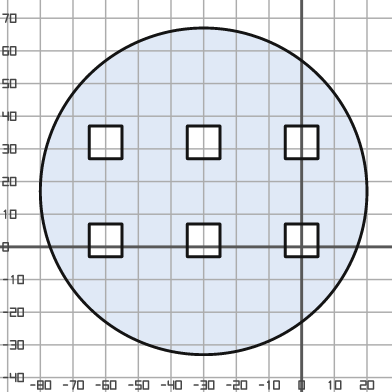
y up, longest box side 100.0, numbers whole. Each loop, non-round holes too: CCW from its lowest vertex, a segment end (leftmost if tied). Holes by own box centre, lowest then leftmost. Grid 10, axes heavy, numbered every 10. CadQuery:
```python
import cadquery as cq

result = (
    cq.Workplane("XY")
    .moveTo(-30.0, 17.0)
    .circle(50.0)
    .moveTo(-65.0, -3.0)
    .lineTo(-55.0, -3.0)
    .lineTo(-55.0, 7.0)
    .lineTo(-65.0, 7.0)
    .close()
    .moveTo(-35.0, -3.0)
    .lineTo(-25.0, -3.0)
    .lineTo(-25.0, 7.0)
    .lineTo(-35.0, 7.0)
    .close()
    .moveTo(-5.0, -3.0)
    .lineTo(5.0, -3.0)
    .lineTo(5.0, 7.0)
    .lineTo(-5.0, 7.0)
    .close()
    .moveTo(-65.0, 27.0)
    .lineTo(-55.0, 27.0)
    .lineTo(-55.0, 37.0)
    .lineTo(-65.0, 37.0)
    .close()
    .moveTo(-35.0, 27.0)
    .lineTo(-25.0, 27.0)
    .lineTo(-25.0, 37.0)
    .lineTo(-35.0, 37.0)
    .close()
    .moveTo(-5.0, 27.0)
    .lineTo(5.0, 27.0)
    .lineTo(5.0, 37.0)
    .lineTo(-5.0, 37.0)
    .close()
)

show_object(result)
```